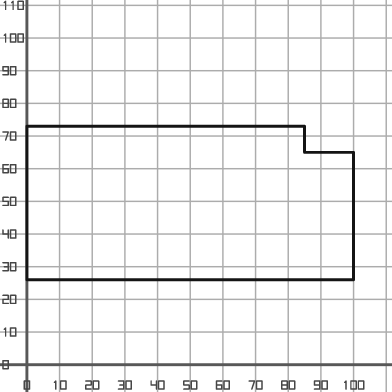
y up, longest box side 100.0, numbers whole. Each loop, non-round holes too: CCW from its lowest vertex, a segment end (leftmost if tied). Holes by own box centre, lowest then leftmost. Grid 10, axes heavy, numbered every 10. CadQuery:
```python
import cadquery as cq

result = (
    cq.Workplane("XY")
    .moveTo(0.0, 26.0)
    .lineTo(100.0, 26.0)
    .lineTo(100.0, 65.0)
    .lineTo(85.0, 65.0)
    .lineTo(85.0, 73.0)
    .lineTo(0.0, 73.0)
    .close()
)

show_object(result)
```